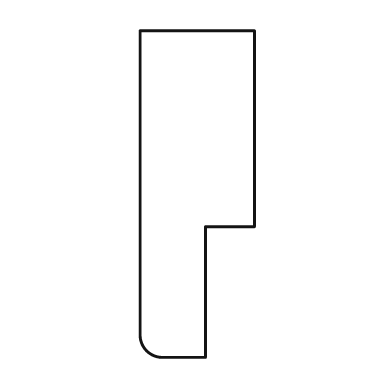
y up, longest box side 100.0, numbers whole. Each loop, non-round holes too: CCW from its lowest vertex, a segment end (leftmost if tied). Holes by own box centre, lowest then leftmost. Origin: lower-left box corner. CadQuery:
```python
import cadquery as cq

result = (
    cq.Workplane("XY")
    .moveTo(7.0, 0.0)
    .lineTo(20.0, 0.0)
    .lineTo(20.0, 40.0)
    .lineTo(35.0, 40.0)
    .lineTo(35.0, 100.0)
    .lineTo(0.0, 100.0)
    .lineTo(0.0, 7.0)
    .threePointArc((2.0, 2.0), (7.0, 0.0))
    .close()
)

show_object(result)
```